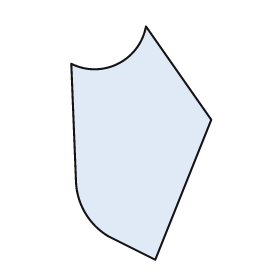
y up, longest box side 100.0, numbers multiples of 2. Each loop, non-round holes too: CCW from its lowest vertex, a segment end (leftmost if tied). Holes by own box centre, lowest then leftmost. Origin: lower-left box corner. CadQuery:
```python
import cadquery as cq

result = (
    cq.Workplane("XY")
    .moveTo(36.0, 0.0)
    .lineTo(60.0, 60.0)
    .lineTo(32.0, 100.0)
    .threePointArc((20.0, 84.0), (0.0, 84.0))
    .lineTo(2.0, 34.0)
    .threePointArc((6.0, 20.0), (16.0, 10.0))
    .close()
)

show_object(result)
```